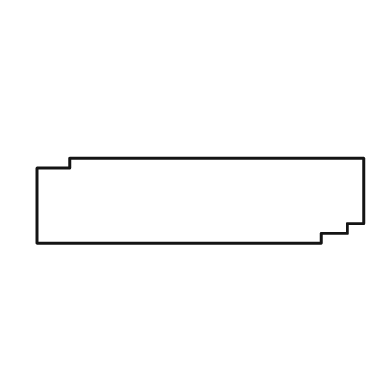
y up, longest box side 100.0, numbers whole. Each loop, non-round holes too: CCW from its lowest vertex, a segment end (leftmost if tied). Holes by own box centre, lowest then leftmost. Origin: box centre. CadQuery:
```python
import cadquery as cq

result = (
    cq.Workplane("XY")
    .moveTo(-50.0, -13.0)
    .lineTo(37.0, -13.0)
    .lineTo(37.0, -10.0)
    .lineTo(45.0, -10.0)
    .lineTo(45.0, -7.0)
    .lineTo(50.0, -7.0)
    .lineTo(50.0, 13.0)
    .lineTo(-40.0, 13.0)
    .lineTo(-40.0, 10.0)
    .lineTo(-50.0, 10.0)
    .close()
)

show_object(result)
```